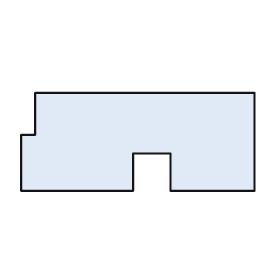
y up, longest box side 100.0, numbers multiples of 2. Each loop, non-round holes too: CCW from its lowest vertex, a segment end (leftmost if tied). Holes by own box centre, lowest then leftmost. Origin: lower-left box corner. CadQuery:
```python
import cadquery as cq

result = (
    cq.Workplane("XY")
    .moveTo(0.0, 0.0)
    .lineTo(48.0, 0.0)
    .lineTo(48.0, 16.0)
    .lineTo(64.0, 16.0)
    .lineTo(64.0, 0.0)
    .lineTo(100.0, 0.0)
    .lineTo(100.0, 42.0)
    .lineTo(6.0, 42.0)
    .lineTo(6.0, 24.0)
    .lineTo(0.0, 24.0)
    .close()
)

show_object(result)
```